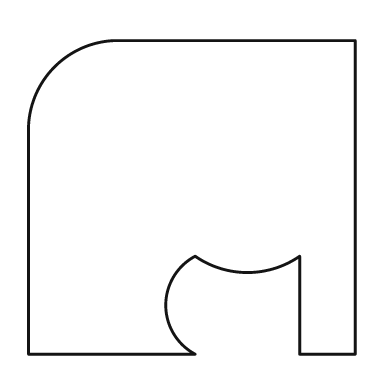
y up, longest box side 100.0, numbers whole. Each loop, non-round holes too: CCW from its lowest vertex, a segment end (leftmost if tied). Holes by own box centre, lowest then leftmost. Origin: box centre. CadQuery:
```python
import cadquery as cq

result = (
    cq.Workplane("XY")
    .moveTo(-50.0, -48.0)
    .lineTo(1.0, -48.0)
    .threePointArc((-8.0, -33.0), (1.0, -18.0))
    .threePointArc((17.0, -23.0), (33.0, -18.0))
    .lineTo(33.0, -48.0)
    .lineTo(50.0, -48.0)
    .lineTo(50.0, 48.0)
    .lineTo(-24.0, 48.0)
    .threePointArc((-42.0, 40.0), (-50.0, 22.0))
    .close()
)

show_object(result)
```